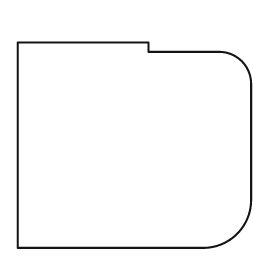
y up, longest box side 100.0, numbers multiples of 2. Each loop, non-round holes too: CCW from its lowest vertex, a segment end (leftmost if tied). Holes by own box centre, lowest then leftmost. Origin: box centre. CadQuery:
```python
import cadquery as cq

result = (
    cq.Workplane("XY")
    .moveTo(-50.0, -44.0)
    .lineTo(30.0, -44.0)
    .threePointArc((44.0, -38.0), (50.0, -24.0))
    .lineTo(50.0, 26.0)
    .threePointArc((46.0, 36.0), (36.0, 40.0))
    .lineTo(6.0, 40.0)
    .lineTo(6.0, 44.0)
    .lineTo(-50.0, 44.0)
    .close()
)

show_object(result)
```